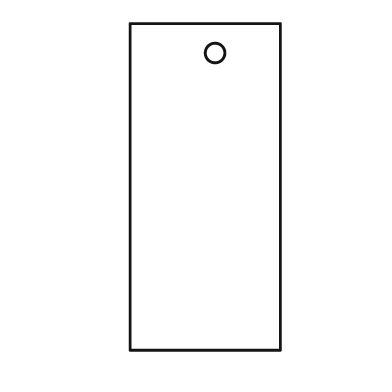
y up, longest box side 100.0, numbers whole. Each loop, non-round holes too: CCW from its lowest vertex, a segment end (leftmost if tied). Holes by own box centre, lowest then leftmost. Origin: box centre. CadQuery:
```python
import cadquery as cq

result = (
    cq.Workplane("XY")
    .moveTo(-23.0, -50.0)
    .lineTo(23.0, -50.0)
    .lineTo(23.0, 50.0)
    .lineTo(-23.0, 50.0)
    .close()
    .moveTo(3.0, 41.0)
    .circle(3.0)
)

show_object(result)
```